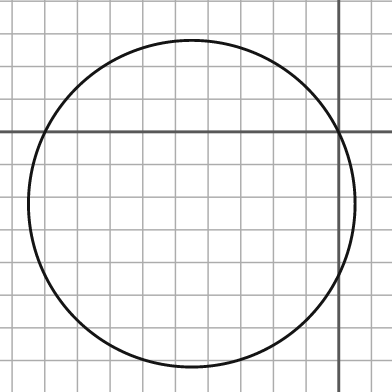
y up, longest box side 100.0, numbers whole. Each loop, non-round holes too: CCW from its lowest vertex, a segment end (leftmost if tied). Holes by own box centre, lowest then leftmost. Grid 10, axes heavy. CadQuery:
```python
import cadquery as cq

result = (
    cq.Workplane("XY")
    .moveTo(-45.0, -22.0)
    .circle(50.0)
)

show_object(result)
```